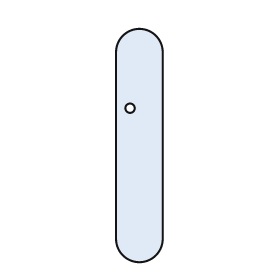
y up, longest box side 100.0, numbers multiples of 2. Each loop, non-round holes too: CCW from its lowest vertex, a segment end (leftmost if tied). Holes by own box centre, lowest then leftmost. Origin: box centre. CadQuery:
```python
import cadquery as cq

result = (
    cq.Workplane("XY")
    .moveTo(-10.0, -40.0)
    .threePointArc((0.0, -50.0), (10.0, -40.0))
    .lineTo(10.0, 40.0)
    .threePointArc((0.0, 50.0), (-10.0, 40.0))
    .close()
    .moveTo(-4.0, 16.0)
    .circle(2.0)
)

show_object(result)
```